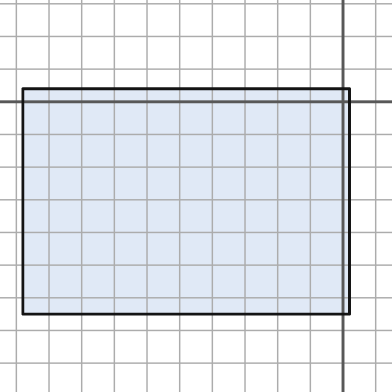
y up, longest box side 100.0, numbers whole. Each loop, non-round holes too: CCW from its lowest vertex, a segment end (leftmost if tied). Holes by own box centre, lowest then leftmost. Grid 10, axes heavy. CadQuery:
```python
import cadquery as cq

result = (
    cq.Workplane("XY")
    .moveTo(-98.0, -65.0)
    .lineTo(2.0, -65.0)
    .lineTo(2.0, 4.0)
    .lineTo(-98.0, 4.0)
    .close()
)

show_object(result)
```